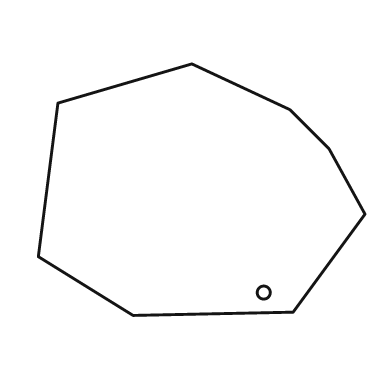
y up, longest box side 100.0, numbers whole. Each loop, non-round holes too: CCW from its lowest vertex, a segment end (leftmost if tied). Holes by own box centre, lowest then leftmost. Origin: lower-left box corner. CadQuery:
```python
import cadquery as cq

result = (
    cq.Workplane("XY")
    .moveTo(29.0, 0.0)
    .lineTo(78.0, 1.0)
    .lineTo(100.0, 31.0)
    .lineTo(89.0, 51.0)
    .lineTo(77.0, 63.0)
    .lineTo(47.0, 77.0)
    .lineTo(6.0, 65.0)
    .lineTo(0.0, 18.0)
    .close()
    .moveTo(69.0, 7.0)
    .circle(2.0)
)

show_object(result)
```